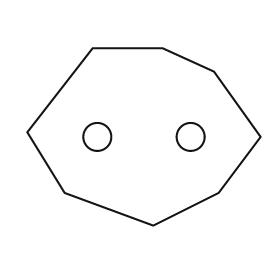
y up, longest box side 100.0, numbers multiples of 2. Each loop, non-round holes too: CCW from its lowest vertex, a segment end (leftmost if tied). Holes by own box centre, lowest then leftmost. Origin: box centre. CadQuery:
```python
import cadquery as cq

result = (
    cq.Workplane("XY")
    .moveTo(4.0, -38.0)
    .lineTo(32.0, -24.0)
    .lineTo(50.0, 0.0)
    .lineTo(30.0, 28.0)
    .lineTo(8.0, 38.0)
    .lineTo(-22.0, 38.0)
    .lineTo(-50.0, 2.0)
    .lineTo(-34.0, -24.0)
    .close()
    .moveTo(-20.0, 0.0)
    .circle(6.0)
    .moveTo(20.0, 0.0)
    .circle(6.0)
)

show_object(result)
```